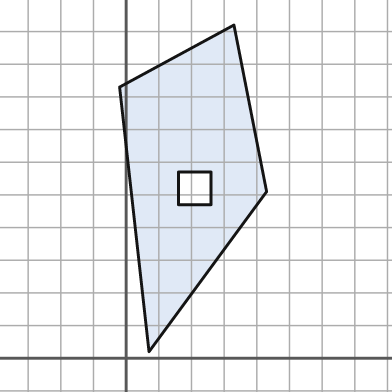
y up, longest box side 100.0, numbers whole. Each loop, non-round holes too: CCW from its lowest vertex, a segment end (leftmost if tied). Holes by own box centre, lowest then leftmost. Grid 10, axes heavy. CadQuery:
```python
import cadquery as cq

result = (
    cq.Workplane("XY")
    .moveTo(7.0, 2.0)
    .lineTo(43.0, 51.0)
    .lineTo(33.0, 102.0)
    .lineTo(-2.0, 83.0)
    .close()
    .moveTo(16.0, 47.0)
    .lineTo(26.0, 47.0)
    .lineTo(26.0, 57.0)
    .lineTo(16.0, 57.0)
    .close()
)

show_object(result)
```